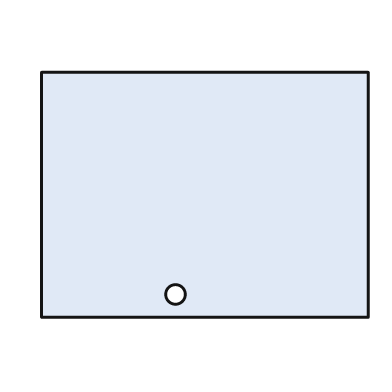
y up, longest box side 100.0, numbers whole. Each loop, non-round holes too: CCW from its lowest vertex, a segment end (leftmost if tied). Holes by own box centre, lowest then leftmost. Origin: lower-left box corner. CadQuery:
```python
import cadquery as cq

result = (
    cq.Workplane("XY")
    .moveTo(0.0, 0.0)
    .lineTo(100.0, 0.0)
    .lineTo(100.0, 75.0)
    .lineTo(0.0, 75.0)
    .close()
    .moveTo(41.0, 7.0)
    .circle(3.0)
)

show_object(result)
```